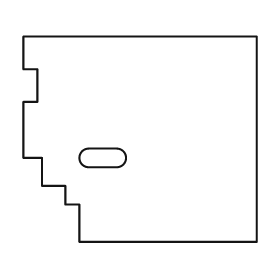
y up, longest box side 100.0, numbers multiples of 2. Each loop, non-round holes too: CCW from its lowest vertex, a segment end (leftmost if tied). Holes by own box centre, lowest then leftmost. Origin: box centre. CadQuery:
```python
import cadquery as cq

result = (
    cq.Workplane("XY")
    .moveTo(-26.0, -44.0)
    .lineTo(50.0, -44.0)
    .lineTo(50.0, 44.0)
    .lineTo(-50.0, 44.0)
    .lineTo(-50.0, 30.0)
    .lineTo(-44.0, 30.0)
    .lineTo(-44.0, 16.0)
    .lineTo(-50.0, 16.0)
    .lineTo(-50.0, -8.0)
    .lineTo(-42.0, -8.0)
    .lineTo(-42.0, -20.0)
    .lineTo(-32.0, -20.0)
    .lineTo(-32.0, -28.0)
    .lineTo(-26.0, -28.0)
    .close()
    .moveTo(-22.0, -12.0)
    .lineTo(-10.0, -12.0)
    .threePointArc((-6.0, -8.0), (-10.0, -4.0))
    .lineTo(-22.0, -4.0)
    .threePointArc((-26.0, -8.0), (-22.0, -12.0))
    .close()
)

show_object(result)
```